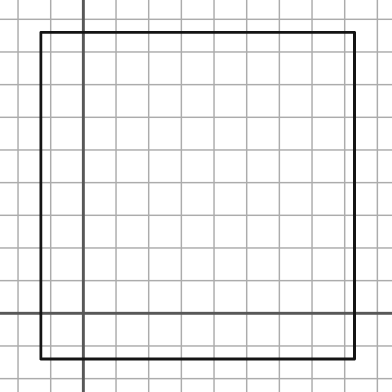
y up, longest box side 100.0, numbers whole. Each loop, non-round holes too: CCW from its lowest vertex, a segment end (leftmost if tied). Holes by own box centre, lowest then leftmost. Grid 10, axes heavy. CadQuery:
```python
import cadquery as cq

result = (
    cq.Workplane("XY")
    .moveTo(-13.0, -14.0)
    .lineTo(83.0, -14.0)
    .lineTo(83.0, 86.0)
    .lineTo(-13.0, 86.0)
    .close()
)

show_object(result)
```